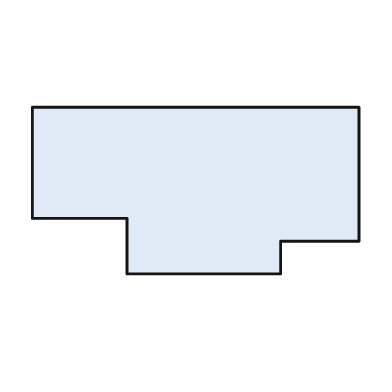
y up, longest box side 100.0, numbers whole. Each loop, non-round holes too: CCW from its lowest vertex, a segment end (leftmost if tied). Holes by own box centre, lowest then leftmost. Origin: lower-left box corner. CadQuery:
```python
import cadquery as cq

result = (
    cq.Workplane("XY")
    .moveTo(29.0, 0.0)
    .lineTo(76.0, 0.0)
    .lineTo(76.0, 10.0)
    .lineTo(100.0, 10.0)
    .lineTo(100.0, 51.0)
    .lineTo(0.0, 51.0)
    .lineTo(0.0, 17.0)
    .lineTo(29.0, 17.0)
    .close()
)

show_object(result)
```